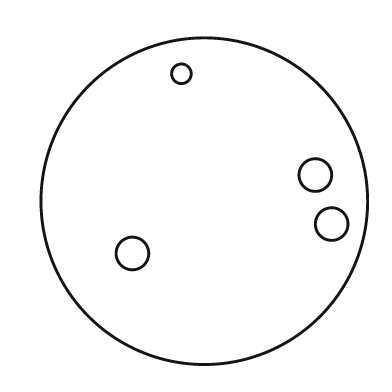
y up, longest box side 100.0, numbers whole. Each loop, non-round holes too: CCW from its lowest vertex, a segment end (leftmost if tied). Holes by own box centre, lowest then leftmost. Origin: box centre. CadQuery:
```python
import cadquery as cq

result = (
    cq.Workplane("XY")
    .moveTo(0.0, 0.0)
    .circle(50.0)
    .moveTo(-22.0, -16.0)
    .circle(5.0)
    .moveTo(39.0, -7.0)
    .circle(5.0)
    .moveTo(34.0, 8.0)
    .circle(5.0)
    .moveTo(-7.0, 39.0)
    .circle(3.0)
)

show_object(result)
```